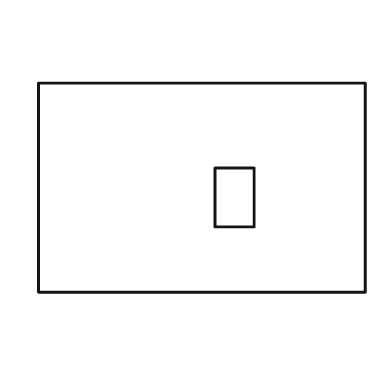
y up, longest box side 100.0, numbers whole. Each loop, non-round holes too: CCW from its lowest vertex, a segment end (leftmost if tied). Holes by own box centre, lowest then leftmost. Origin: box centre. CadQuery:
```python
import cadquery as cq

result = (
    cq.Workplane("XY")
    .moveTo(-50.0, -32.0)
    .lineTo(50.0, -32.0)
    .lineTo(50.0, 32.0)
    .lineTo(-50.0, 32.0)
    .close()
    .moveTo(4.0, -12.0)
    .lineTo(16.0, -12.0)
    .lineTo(16.0, 6.0)
    .lineTo(4.0, 6.0)
    .close()
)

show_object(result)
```